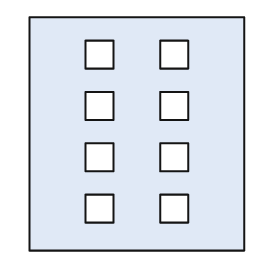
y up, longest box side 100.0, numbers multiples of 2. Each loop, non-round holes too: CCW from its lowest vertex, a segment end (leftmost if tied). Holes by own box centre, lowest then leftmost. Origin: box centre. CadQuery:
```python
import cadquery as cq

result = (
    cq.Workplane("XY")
    .moveTo(-46.0, -50.0)
    .lineTo(46.0, -50.0)
    .lineTo(46.0, 50.0)
    .lineTo(-46.0, 50.0)
    .close()
    .moveTo(-22.0, -38.0)
    .lineTo(-10.0, -38.0)
    .lineTo(-10.0, -26.0)
    .lineTo(-22.0, -26.0)
    .close()
    .moveTo(10.0, -38.0)
    .lineTo(22.0, -38.0)
    .lineTo(22.0, -26.0)
    .lineTo(10.0, -26.0)
    .close()
    .moveTo(-22.0, -16.0)
    .lineTo(-10.0, -16.0)
    .lineTo(-10.0, -4.0)
    .lineTo(-22.0, -4.0)
    .close()
    .moveTo(10.0, -16.0)
    .lineTo(22.0, -16.0)
    .lineTo(22.0, -4.0)
    .lineTo(10.0, -4.0)
    .close()
    .moveTo(-22.0, 6.0)
    .lineTo(-10.0, 6.0)
    .lineTo(-10.0, 18.0)
    .lineTo(-22.0, 18.0)
    .close()
    .moveTo(10.0, 6.0)
    .lineTo(22.0, 6.0)
    .lineTo(22.0, 18.0)
    .lineTo(10.0, 18.0)
    .close()
    .moveTo(-22.0, 28.0)
    .lineTo(-10.0, 28.0)
    .lineTo(-10.0, 40.0)
    .lineTo(-22.0, 40.0)
    .close()
    .moveTo(10.0, 28.0)
    .lineTo(22.0, 28.0)
    .lineTo(22.0, 40.0)
    .lineTo(10.0, 40.0)
    .close()
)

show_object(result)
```